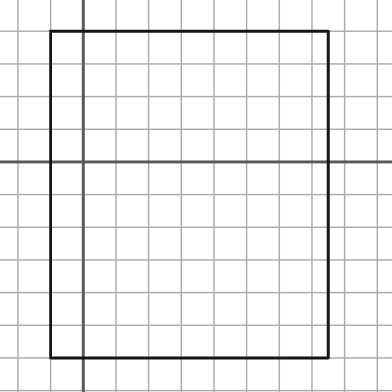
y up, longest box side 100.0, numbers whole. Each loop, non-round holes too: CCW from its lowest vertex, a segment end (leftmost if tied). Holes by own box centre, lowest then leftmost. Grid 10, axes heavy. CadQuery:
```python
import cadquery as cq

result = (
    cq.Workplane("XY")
    .moveTo(-10.0, -60.0)
    .lineTo(75.0, -60.0)
    .lineTo(75.0, 40.0)
    .lineTo(-10.0, 40.0)
    .close()
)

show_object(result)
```